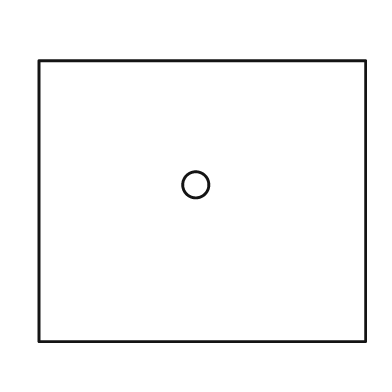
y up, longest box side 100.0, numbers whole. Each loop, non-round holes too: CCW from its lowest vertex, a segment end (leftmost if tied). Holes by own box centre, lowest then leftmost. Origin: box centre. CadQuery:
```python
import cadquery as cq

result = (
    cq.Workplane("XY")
    .moveTo(-50.0, -43.0)
    .lineTo(50.0, -43.0)
    .lineTo(50.0, 43.0)
    .lineTo(-50.0, 43.0)
    .close()
    .moveTo(-2.0, 5.0)
    .circle(4.0)
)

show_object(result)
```